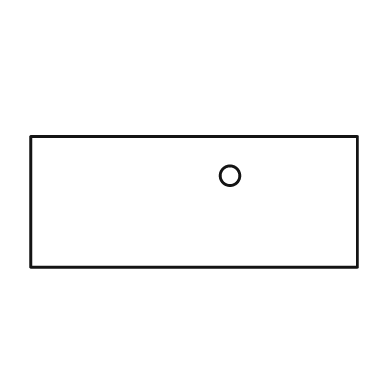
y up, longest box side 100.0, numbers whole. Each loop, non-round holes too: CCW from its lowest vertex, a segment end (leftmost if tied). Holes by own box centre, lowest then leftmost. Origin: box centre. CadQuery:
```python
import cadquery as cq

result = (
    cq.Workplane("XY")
    .moveTo(-50.0, -20.0)
    .lineTo(50.0, -20.0)
    .lineTo(50.0, 20.0)
    .lineTo(-50.0, 20.0)
    .close()
    .moveTo(11.0, 8.0)
    .circle(3.0)
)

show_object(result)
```